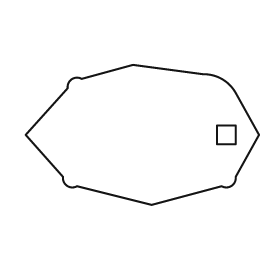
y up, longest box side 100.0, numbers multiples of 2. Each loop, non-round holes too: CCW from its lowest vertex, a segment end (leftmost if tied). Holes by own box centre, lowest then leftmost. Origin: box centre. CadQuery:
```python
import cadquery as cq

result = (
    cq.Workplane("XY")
    .moveTo(4.0, -30.0)
    .lineTo(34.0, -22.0)
    .threePointArc((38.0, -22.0), (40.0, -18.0))
    .lineTo(50.0, 0.0)
    .lineTo(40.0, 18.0)
    .threePointArc((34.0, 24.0), (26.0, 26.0))
    .lineTo(-4.0, 30.0)
    .lineTo(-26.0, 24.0)
    .threePointArc((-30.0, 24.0), (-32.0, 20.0))
    .lineTo(-50.0, 0.0)
    .lineTo(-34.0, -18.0)
    .threePointArc((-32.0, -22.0), (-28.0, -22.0))
    .close()
    .moveTo(32.0, -4.0)
    .lineTo(40.0, -4.0)
    .lineTo(40.0, 4.0)
    .lineTo(32.0, 4.0)
    .close()
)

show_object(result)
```